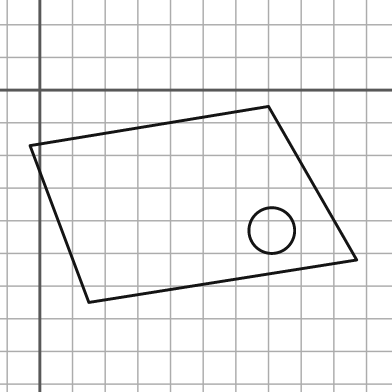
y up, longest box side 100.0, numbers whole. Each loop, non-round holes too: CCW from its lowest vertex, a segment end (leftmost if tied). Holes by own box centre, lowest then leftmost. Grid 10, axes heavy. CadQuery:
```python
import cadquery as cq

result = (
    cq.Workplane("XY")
    .moveTo(15.0, -65.0)
    .lineTo(97.0, -52.0)
    .lineTo(70.0, -5.0)
    .lineTo(-3.0, -17.0)
    .close()
    .moveTo(71.0, -43.0)
    .circle(7.0)
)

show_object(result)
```